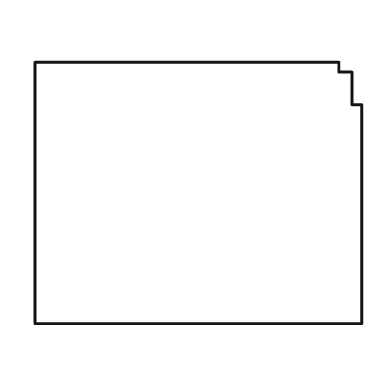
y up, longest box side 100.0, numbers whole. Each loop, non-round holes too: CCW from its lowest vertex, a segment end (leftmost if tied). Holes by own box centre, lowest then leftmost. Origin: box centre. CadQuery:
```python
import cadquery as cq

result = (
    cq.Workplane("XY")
    .moveTo(-50.0, -40.0)
    .lineTo(50.0, -40.0)
    .lineTo(50.0, 27.0)
    .lineTo(47.0, 27.0)
    .lineTo(47.0, 37.0)
    .lineTo(43.0, 37.0)
    .lineTo(43.0, 40.0)
    .lineTo(-50.0, 40.0)
    .close()
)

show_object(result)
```